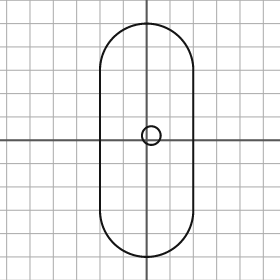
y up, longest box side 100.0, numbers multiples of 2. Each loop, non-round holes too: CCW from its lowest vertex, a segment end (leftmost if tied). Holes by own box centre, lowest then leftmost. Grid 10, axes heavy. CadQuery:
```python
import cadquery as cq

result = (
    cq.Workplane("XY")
    .moveTo(-20.0, -30.0)
    .threePointArc((0.0, -50.0), (20.0, -30.0))
    .lineTo(20.0, 30.0)
    .threePointArc((0.0, 50.0), (-20.0, 30.0))
    .close()
    .moveTo(2.0, 2.0)
    .circle(4.0)
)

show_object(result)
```